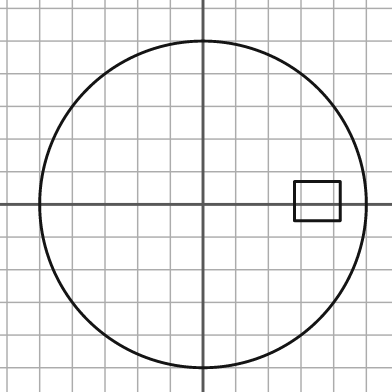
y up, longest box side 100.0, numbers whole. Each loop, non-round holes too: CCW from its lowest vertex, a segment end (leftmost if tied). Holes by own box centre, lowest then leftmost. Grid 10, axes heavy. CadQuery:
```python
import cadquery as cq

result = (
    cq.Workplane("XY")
    .moveTo(0.0, 0.0)
    .circle(50.0)
    .moveTo(28.0, -5.0)
    .lineTo(42.0, -5.0)
    .lineTo(42.0, 7.0)
    .lineTo(28.0, 7.0)
    .close()
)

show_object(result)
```